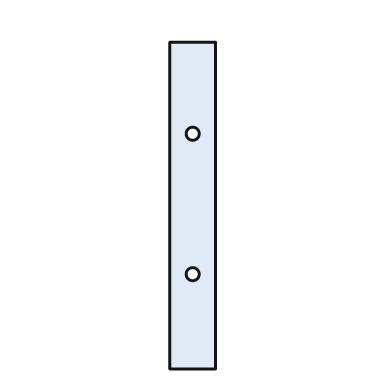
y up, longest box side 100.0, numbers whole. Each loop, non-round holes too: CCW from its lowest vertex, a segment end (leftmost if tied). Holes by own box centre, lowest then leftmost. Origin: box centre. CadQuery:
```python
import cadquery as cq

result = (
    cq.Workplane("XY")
    .moveTo(-7.0, -50.0)
    .lineTo(7.0, -50.0)
    .lineTo(7.0, 50.0)
    .lineTo(-7.0, 50.0)
    .close()
    .moveTo(0.0, -21.0)
    .circle(2.0)
    .moveTo(0.0, 22.0)
    .circle(2.0)
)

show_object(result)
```